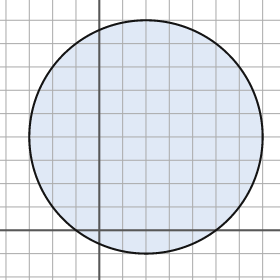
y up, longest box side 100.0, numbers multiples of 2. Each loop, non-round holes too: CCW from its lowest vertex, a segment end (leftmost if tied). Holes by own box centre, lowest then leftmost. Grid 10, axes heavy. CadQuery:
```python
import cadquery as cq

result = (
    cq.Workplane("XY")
    .moveTo(20.0, 40.0)
    .circle(50.0)
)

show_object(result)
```